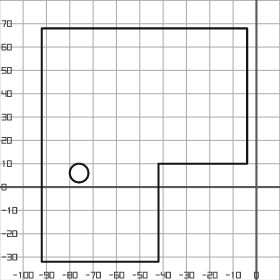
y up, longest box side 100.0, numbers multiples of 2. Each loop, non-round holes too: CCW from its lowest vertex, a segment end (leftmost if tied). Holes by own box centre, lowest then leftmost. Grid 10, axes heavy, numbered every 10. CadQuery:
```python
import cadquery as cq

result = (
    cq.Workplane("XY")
    .moveTo(-92.0, -32.0)
    .lineTo(-42.0, -32.0)
    .lineTo(-42.0, 10.0)
    .lineTo(-4.0, 10.0)
    .lineTo(-4.0, 68.0)
    .lineTo(-92.0, 68.0)
    .close()
    .moveTo(-76.0, 6.0)
    .circle(4.0)
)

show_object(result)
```